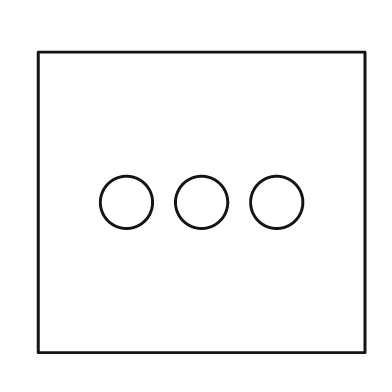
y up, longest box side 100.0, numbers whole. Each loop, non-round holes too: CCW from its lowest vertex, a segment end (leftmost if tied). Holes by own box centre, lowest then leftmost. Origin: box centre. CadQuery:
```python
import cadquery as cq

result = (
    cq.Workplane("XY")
    .moveTo(-50.0, -46.0)
    .lineTo(50.0, -46.0)
    .lineTo(50.0, 46.0)
    .lineTo(-50.0, 46.0)
    .close()
    .moveTo(-23.0, 0.0)
    .circle(8.0)
    .moveTo(0.0, 0.0)
    .circle(8.0)
    .moveTo(23.0, 0.0)
    .circle(8.0)
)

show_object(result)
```